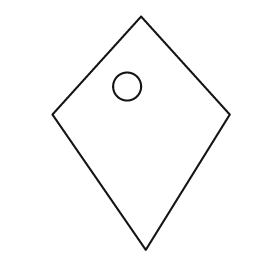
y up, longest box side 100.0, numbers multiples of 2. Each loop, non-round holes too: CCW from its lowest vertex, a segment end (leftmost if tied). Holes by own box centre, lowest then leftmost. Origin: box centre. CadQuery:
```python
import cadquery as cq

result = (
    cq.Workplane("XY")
    .moveTo(2.0, -50.0)
    .lineTo(38.0, 8.0)
    .lineTo(0.0, 50.0)
    .lineTo(-38.0, 8.0)
    .close()
    .moveTo(-6.0, 20.0)
    .circle(6.0)
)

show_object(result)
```